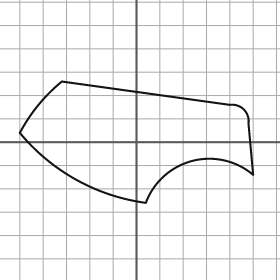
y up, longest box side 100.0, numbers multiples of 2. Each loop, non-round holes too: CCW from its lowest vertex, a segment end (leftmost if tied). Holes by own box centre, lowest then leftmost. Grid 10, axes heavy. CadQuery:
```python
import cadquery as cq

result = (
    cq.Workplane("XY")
    .moveTo(4.0, -26.0)
    .threePointArc((24.0, -8.0), (50.0, -14.0))
    .lineTo(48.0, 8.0)
    .threePointArc((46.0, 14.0), (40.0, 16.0))
    .lineTo(-32.0, 26.0)
    .threePointArc((-42.0, 16.0), (-50.0, 4.0))
    .threePointArc((-26.0, -16.0), (4.0, -26.0))
    .close()
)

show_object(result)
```